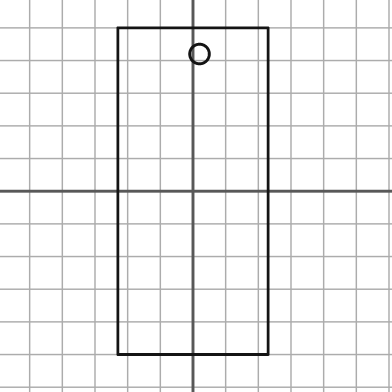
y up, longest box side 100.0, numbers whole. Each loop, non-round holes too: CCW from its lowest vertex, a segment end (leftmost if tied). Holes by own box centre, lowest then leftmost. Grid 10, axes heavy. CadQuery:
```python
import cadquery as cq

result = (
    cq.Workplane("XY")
    .moveTo(-23.0, -50.0)
    .lineTo(23.0, -50.0)
    .lineTo(23.0, 50.0)
    .lineTo(-23.0, 50.0)
    .close()
    .moveTo(2.0, 42.0)
    .circle(3.0)
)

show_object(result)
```